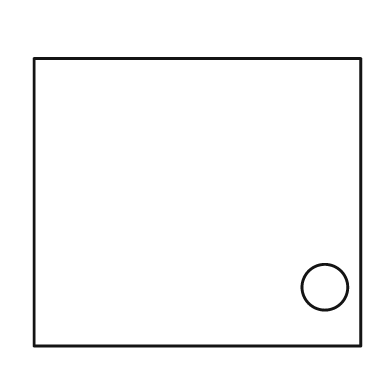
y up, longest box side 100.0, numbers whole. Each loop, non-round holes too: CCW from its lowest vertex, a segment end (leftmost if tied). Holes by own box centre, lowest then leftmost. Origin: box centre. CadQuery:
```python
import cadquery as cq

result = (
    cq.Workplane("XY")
    .moveTo(-50.0, -44.0)
    .lineTo(50.0, -44.0)
    .lineTo(50.0, 44.0)
    .lineTo(-50.0, 44.0)
    .close()
    .moveTo(39.0, -26.0)
    .circle(7.0)
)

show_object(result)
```